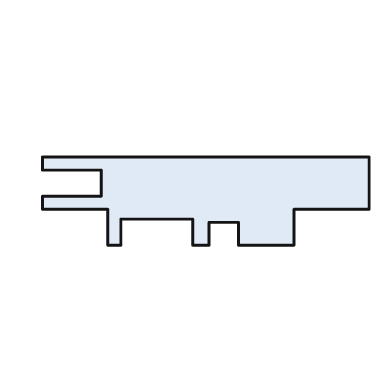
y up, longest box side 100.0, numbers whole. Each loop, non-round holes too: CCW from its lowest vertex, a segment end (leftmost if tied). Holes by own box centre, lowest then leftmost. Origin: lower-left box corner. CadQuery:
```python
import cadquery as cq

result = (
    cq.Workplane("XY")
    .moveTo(20.0, 0.0)
    .lineTo(24.0, 0.0)
    .lineTo(24.0, 8.0)
    .lineTo(46.0, 8.0)
    .lineTo(46.0, 0.0)
    .lineTo(51.0, 0.0)
    .lineTo(51.0, 7.0)
    .lineTo(60.0, 7.0)
    .lineTo(60.0, 0.0)
    .lineTo(77.0, 0.0)
    .lineTo(77.0, 11.0)
    .lineTo(100.0, 11.0)
    .lineTo(100.0, 27.0)
    .lineTo(0.0, 27.0)
    .lineTo(0.0, 23.0)
    .lineTo(18.0, 23.0)
    .lineTo(18.0, 15.0)
    .lineTo(0.0, 15.0)
    .lineTo(0.0, 11.0)
    .lineTo(20.0, 11.0)
    .close()
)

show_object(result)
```